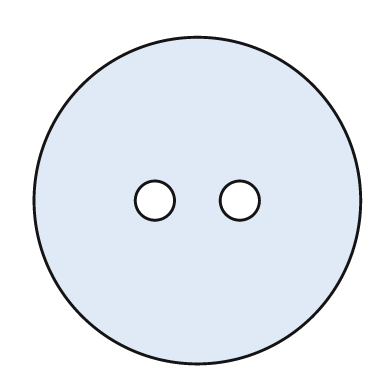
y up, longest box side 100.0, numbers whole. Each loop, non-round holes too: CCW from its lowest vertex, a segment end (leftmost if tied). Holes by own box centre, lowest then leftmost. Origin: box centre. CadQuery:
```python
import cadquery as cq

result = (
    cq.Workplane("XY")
    .moveTo(0.0, 0.0)
    .circle(50.0)
    .moveTo(-13.0, 0.0)
    .circle(6.0)
    .moveTo(13.0, 0.0)
    .circle(6.0)
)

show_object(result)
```